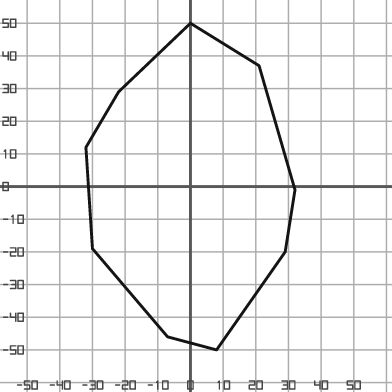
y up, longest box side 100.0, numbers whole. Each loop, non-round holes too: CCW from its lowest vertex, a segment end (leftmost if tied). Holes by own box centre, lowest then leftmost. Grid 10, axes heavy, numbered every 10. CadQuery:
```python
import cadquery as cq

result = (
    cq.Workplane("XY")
    .moveTo(8.0, -50.0)
    .lineTo(29.0, -20.0)
    .lineTo(32.0, -1.0)
    .lineTo(21.0, 37.0)
    .lineTo(0.0, 50.0)
    .lineTo(-22.0, 29.0)
    .lineTo(-32.0, 12.0)
    .lineTo(-30.0, -19.0)
    .lineTo(-7.0, -46.0)
    .close()
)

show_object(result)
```